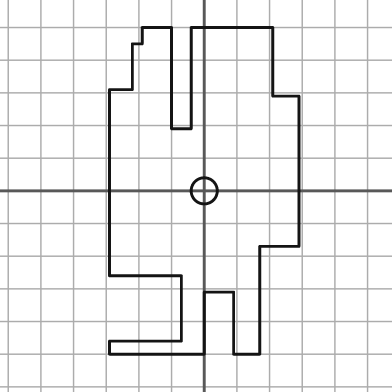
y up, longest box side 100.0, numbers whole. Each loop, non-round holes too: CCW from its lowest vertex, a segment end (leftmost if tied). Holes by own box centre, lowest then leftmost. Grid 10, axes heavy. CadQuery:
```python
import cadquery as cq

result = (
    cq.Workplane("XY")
    .moveTo(-29.0, -50.0)
    .lineTo(0.0, -50.0)
    .lineTo(0.0, -31.0)
    .lineTo(9.0, -31.0)
    .lineTo(9.0, -50.0)
    .lineTo(17.0, -50.0)
    .lineTo(17.0, -17.0)
    .lineTo(29.0, -17.0)
    .lineTo(29.0, 29.0)
    .lineTo(21.0, 29.0)
    .lineTo(21.0, 50.0)
    .lineTo(-4.0, 50.0)
    .lineTo(-4.0, 19.0)
    .lineTo(-10.0, 19.0)
    .lineTo(-10.0, 50.0)
    .lineTo(-19.0, 50.0)
    .lineTo(-19.0, 45.0)
    .lineTo(-22.0, 45.0)
    .lineTo(-22.0, 31.0)
    .lineTo(-29.0, 31.0)
    .lineTo(-29.0, -26.0)
    .lineTo(-7.0, -26.0)
    .lineTo(-7.0, -46.0)
    .lineTo(-29.0, -46.0)
    .close()
    .moveTo(0.0, 0.0)
    .circle(4.0)
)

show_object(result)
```